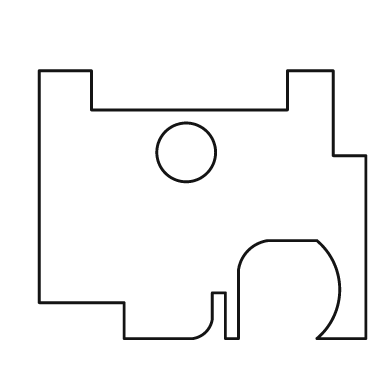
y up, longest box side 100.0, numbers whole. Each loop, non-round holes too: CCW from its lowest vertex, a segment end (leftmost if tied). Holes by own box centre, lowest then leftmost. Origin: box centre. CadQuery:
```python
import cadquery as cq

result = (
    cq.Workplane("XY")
    .moveTo(-24.0, -41.0)
    .lineTo(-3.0, -41.0)
    .threePointArc((1.0, -39.0), (3.0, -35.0))
    .lineTo(3.0, -27.0)
    .lineTo(7.0, -27.0)
    .lineTo(7.0, -41.0)
    .lineTo(11.0, -41.0)
    .lineTo(11.0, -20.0)
    .threePointArc((14.0, -14.0), (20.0, -11.0))
    .lineTo(35.0, -11.0)
    .threePointArc((42.0, -26.0), (35.0, -41.0))
    .lineTo(50.0, -41.0)
    .lineTo(50.0, 15.0)
    .lineTo(40.0, 15.0)
    .lineTo(40.0, 41.0)
    .lineTo(26.0, 41.0)
    .lineTo(26.0, 29.0)
    .lineTo(-34.0, 29.0)
    .lineTo(-34.0, 41.0)
    .lineTo(-50.0, 41.0)
    .lineTo(-50.0, -30.0)
    .lineTo(-24.0, -30.0)
    .close()
    .moveTo(-5.0, 16.0)
    .circle(9.0)
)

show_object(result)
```